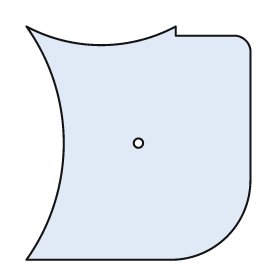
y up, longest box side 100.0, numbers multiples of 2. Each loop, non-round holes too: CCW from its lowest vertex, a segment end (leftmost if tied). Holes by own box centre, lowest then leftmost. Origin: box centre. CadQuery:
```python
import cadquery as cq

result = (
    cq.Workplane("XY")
    .moveTo(-48.0, -50.0)
    .lineTo(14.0, -50.0)
    .threePointArc((38.0, -40.0), (48.0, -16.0))
    .lineTo(48.0, 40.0)
    .threePointArc((46.0, 44.0), (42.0, 46.0))
    .lineTo(16.0, 46.0)
    .lineTo(16.0, 50.0)
    .threePointArc((-16.0, 42.0), (-48.0, 50.0))
    .threePointArc((-32.0, 0.0), (-48.0, -50.0))
    .close()
    .moveTo(0.0, 0.0)
    .circle(2.0)
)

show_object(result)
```